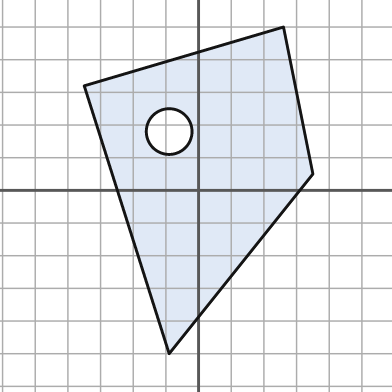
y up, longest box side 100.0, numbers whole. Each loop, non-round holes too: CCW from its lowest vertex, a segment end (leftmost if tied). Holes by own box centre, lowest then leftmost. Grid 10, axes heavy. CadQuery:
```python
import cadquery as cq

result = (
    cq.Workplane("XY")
    .moveTo(-9.0, -50.0)
    .lineTo(35.0, 5.0)
    .lineTo(26.0, 50.0)
    .lineTo(-35.0, 32.0)
    .close()
    .moveTo(-9.0, 18.0)
    .circle(7.0)
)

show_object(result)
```